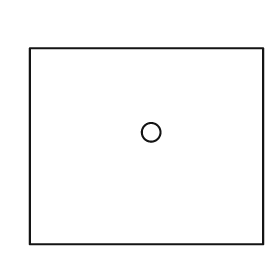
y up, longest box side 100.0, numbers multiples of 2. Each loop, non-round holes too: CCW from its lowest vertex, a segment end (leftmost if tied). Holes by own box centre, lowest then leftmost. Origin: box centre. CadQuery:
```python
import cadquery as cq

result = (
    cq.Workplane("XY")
    .moveTo(-50.0, -42.0)
    .lineTo(50.0, -42.0)
    .lineTo(50.0, 42.0)
    .lineTo(-50.0, 42.0)
    .close()
    .moveTo(2.0, 6.0)
    .circle(4.0)
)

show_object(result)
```